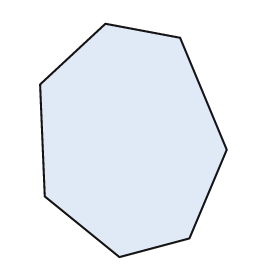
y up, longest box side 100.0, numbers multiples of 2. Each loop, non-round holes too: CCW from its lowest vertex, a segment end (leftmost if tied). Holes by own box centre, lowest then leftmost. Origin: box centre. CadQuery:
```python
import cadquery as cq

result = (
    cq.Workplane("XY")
    .moveTo(-6.0, -50.0)
    .lineTo(24.0, -42.0)
    .lineTo(40.0, -4.0)
    .lineTo(20.0, 44.0)
    .lineTo(-12.0, 50.0)
    .lineTo(-40.0, 24.0)
    .lineTo(-38.0, -24.0)
    .close()
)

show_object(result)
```